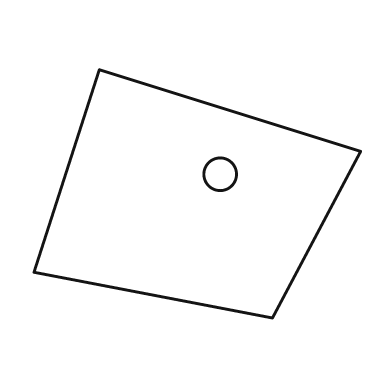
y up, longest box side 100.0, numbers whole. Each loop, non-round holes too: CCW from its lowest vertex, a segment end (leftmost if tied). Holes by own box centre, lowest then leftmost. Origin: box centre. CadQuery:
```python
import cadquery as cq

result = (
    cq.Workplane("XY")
    .moveTo(23.0, -38.0)
    .lineTo(50.0, 13.0)
    .lineTo(-30.0, 38.0)
    .lineTo(-50.0, -24.0)
    .close()
    .moveTo(7.0, 6.0)
    .circle(5.0)
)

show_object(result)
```